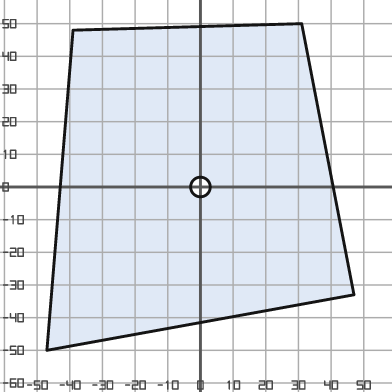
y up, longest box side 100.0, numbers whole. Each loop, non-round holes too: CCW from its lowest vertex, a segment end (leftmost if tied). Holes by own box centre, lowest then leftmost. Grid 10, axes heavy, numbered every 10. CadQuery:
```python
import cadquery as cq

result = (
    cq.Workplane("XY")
    .moveTo(-47.0, -50.0)
    .lineTo(47.0, -33.0)
    .lineTo(31.0, 50.0)
    .lineTo(-39.0, 48.0)
    .close()
    .moveTo(0.0, 0.0)
    .circle(3.0)
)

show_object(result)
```